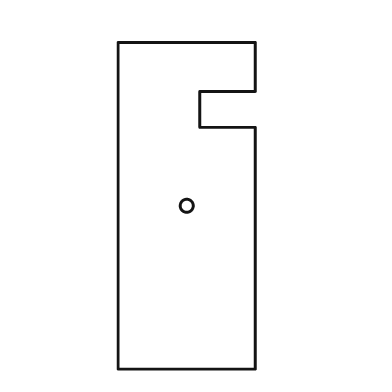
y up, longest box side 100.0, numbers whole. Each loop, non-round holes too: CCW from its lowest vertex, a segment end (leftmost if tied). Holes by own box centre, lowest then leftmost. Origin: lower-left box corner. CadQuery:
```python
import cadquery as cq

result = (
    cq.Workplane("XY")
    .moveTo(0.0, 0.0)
    .lineTo(42.0, 0.0)
    .lineTo(42.0, 74.0)
    .lineTo(25.0, 74.0)
    .lineTo(25.0, 85.0)
    .lineTo(42.0, 85.0)
    .lineTo(42.0, 100.0)
    .lineTo(0.0, 100.0)
    .close()
    .moveTo(21.0, 50.0)
    .circle(2.0)
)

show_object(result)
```